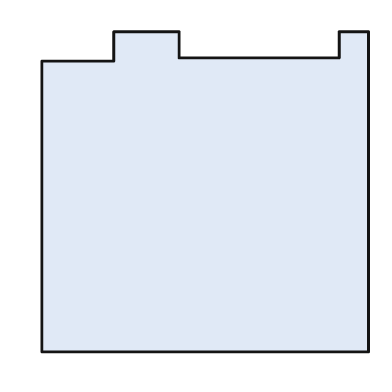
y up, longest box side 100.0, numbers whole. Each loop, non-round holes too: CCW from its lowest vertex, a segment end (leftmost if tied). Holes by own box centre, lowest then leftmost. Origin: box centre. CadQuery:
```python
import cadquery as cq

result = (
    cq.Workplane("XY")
    .moveTo(-50.0, -49.0)
    .lineTo(50.0, -49.0)
    .lineTo(50.0, 49.0)
    .lineTo(41.0, 49.0)
    .lineTo(41.0, 41.0)
    .lineTo(-8.0, 41.0)
    .lineTo(-8.0, 49.0)
    .lineTo(-28.0, 49.0)
    .lineTo(-28.0, 40.0)
    .lineTo(-50.0, 40.0)
    .close()
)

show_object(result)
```